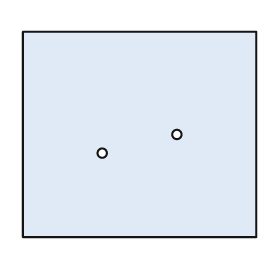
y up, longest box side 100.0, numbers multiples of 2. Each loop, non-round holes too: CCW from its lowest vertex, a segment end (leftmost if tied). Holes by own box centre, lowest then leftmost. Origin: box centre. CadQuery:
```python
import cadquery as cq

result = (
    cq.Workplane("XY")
    .moveTo(-50.0, -44.0)
    .lineTo(50.0, -44.0)
    .lineTo(50.0, 44.0)
    .lineTo(-50.0, 44.0)
    .close()
    .moveTo(-16.0, -8.0)
    .circle(2.0)
    .moveTo(16.0, 0.0)
    .circle(2.0)
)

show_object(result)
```